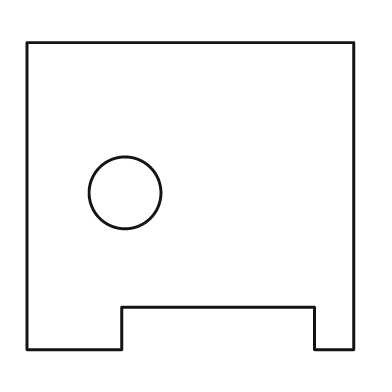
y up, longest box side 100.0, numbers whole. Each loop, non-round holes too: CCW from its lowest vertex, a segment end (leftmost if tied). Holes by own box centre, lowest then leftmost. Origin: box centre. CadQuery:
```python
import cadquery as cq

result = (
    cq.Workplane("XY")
    .moveTo(-50.0, -47.0)
    .lineTo(-21.0, -47.0)
    .lineTo(-21.0, -34.0)
    .lineTo(38.0, -34.0)
    .lineTo(38.0, -47.0)
    .lineTo(50.0, -47.0)
    .lineTo(50.0, 47.0)
    .lineTo(-50.0, 47.0)
    .close()
    .moveTo(-20.0, 1.0)
    .circle(11.0)
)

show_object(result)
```